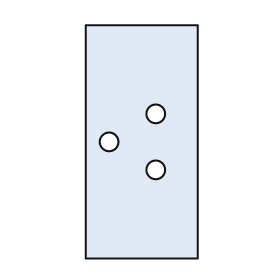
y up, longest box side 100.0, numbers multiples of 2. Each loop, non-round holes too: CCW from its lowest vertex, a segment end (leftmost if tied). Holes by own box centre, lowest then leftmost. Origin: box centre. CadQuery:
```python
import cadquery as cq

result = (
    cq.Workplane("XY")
    .moveTo(-24.0, -50.0)
    .lineTo(24.0, -50.0)
    .lineTo(24.0, 50.0)
    .lineTo(-24.0, 50.0)
    .close()
    .moveTo(6.0, -12.0)
    .circle(4.0)
    .moveTo(-14.0, 0.0)
    .circle(4.0)
    .moveTo(6.0, 12.0)
    .circle(4.0)
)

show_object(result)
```